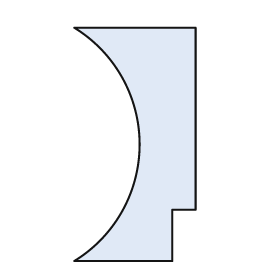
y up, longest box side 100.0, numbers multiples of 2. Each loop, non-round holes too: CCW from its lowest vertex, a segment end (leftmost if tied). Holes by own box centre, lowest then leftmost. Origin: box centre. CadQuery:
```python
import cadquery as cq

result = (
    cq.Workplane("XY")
    .moveTo(-26.0, -50.0)
    .lineTo(16.0, -50.0)
    .lineTo(16.0, -28.0)
    .lineTo(26.0, -28.0)
    .lineTo(26.0, 50.0)
    .lineTo(-26.0, 50.0)
    .threePointArc((2.0, 0.0), (-26.0, -50.0))
    .close()
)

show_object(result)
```